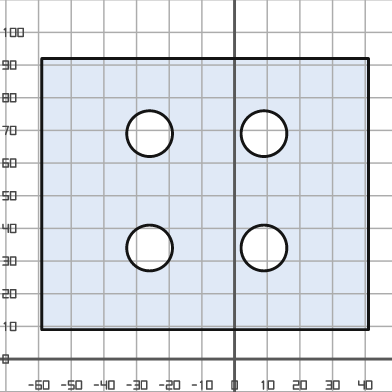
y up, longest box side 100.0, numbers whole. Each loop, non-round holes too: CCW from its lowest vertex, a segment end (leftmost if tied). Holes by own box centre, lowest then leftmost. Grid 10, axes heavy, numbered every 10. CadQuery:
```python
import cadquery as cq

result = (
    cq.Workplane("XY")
    .moveTo(-59.0, 9.0)
    .lineTo(41.0, 9.0)
    .lineTo(41.0, 92.0)
    .lineTo(-59.0, 92.0)
    .close()
    .moveTo(-26.0, 34.0)
    .circle(7.0)
    .moveTo(9.0, 34.0)
    .circle(7.0)
    .moveTo(-26.0, 69.0)
    .circle(7.0)
    .moveTo(9.0, 69.0)
    .circle(7.0)
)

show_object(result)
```